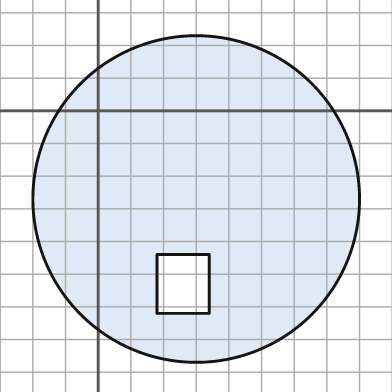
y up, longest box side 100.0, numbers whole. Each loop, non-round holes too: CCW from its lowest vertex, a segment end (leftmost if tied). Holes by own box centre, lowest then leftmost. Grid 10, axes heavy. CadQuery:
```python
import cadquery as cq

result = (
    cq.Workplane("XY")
    .moveTo(30.0, -27.0)
    .circle(50.0)
    .moveTo(18.0, -62.0)
    .lineTo(34.0, -62.0)
    .lineTo(34.0, -44.0)
    .lineTo(18.0, -44.0)
    .close()
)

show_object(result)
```